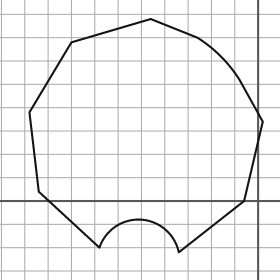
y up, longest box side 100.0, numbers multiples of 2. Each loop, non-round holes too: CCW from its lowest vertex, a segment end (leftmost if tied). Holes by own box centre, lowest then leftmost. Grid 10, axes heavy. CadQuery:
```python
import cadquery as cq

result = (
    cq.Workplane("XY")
    .moveTo(-34.0, -22.0)
    .lineTo(-6.0, 0.0)
    .lineTo(2.0, 34.0)
    .lineTo(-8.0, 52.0)
    .threePointArc((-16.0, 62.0), (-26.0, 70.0))
    .lineTo(-46.0, 78.0)
    .lineTo(-80.0, 68.0)
    .lineTo(-98.0, 38.0)
    .lineTo(-94.0, 4.0)
    .lineTo(-68.0, -20.0)
    .threePointArc((-50.0, -8.0), (-34.0, -22.0))
    .close()
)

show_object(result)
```